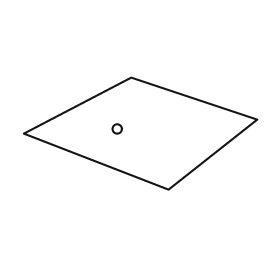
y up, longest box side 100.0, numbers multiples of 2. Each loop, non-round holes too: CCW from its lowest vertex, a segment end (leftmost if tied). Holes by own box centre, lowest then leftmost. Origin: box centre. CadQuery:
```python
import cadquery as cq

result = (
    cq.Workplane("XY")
    .moveTo(12.0, -24.0)
    .lineTo(50.0, 6.0)
    .lineTo(-4.0, 24.0)
    .lineTo(-50.0, 0.0)
    .close()
    .moveTo(-10.0, 2.0)
    .circle(2.0)
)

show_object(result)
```